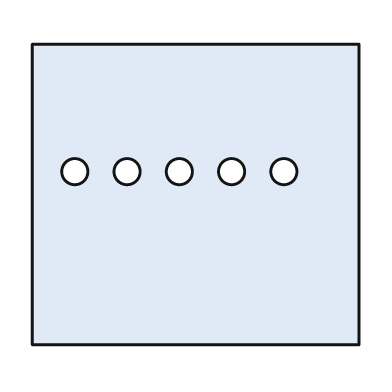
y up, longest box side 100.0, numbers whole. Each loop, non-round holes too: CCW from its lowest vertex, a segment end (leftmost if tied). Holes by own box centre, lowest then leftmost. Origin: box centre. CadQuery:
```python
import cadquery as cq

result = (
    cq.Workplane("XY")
    .moveTo(-50.0, -46.0)
    .lineTo(50.0, -46.0)
    .lineTo(50.0, 46.0)
    .lineTo(-50.0, 46.0)
    .close()
    .moveTo(-37.0, 7.0)
    .circle(4.0)
    .moveTo(-21.0, 7.0)
    .circle(4.0)
    .moveTo(-5.0, 7.0)
    .circle(4.0)
    .moveTo(11.0, 7.0)
    .circle(4.0)
    .moveTo(27.0, 7.0)
    .circle(4.0)
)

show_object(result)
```